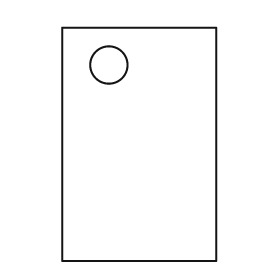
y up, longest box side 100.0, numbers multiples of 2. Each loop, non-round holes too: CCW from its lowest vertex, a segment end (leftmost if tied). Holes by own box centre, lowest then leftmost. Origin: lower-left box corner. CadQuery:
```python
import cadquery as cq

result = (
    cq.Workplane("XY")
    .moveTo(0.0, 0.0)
    .lineTo(66.0, 0.0)
    .lineTo(66.0, 100.0)
    .lineTo(0.0, 100.0)
    .close()
    .moveTo(20.0, 84.0)
    .circle(8.0)
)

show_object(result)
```